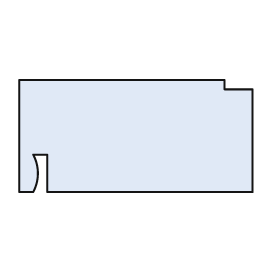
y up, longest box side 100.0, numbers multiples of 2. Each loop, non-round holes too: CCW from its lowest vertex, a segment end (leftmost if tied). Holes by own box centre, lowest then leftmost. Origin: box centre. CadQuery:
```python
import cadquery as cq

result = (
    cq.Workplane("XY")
    .moveTo(-50.0, -24.0)
    .lineTo(-44.0, -24.0)
    .threePointArc((-42.0, -16.0), (-44.0, -8.0))
    .lineTo(-38.0, -8.0)
    .lineTo(-38.0, -24.0)
    .lineTo(50.0, -24.0)
    .lineTo(50.0, 20.0)
    .lineTo(38.0, 20.0)
    .lineTo(38.0, 24.0)
    .lineTo(-50.0, 24.0)
    .close()
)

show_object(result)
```